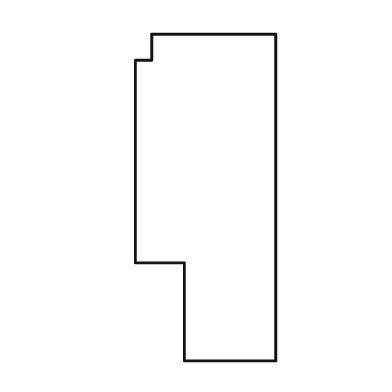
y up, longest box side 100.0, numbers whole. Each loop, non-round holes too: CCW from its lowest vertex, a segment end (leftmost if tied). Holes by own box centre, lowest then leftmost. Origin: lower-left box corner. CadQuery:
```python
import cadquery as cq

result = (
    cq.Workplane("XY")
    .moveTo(15.0, 0.0)
    .lineTo(43.0, 0.0)
    .lineTo(43.0, 100.0)
    .lineTo(5.0, 100.0)
    .lineTo(5.0, 92.0)
    .lineTo(0.0, 92.0)
    .lineTo(0.0, 30.0)
    .lineTo(15.0, 30.0)
    .close()
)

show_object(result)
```